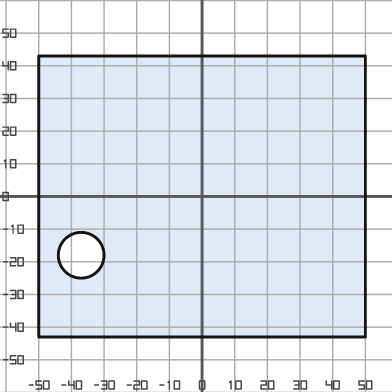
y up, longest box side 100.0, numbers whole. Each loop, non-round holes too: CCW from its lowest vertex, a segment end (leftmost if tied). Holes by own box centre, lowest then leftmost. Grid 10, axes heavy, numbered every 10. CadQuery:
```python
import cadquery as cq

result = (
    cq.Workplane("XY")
    .moveTo(-50.0, -43.0)
    .lineTo(50.0, -43.0)
    .lineTo(50.0, 43.0)
    .lineTo(-50.0, 43.0)
    .close()
    .moveTo(-37.0, -18.0)
    .circle(7.0)
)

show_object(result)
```